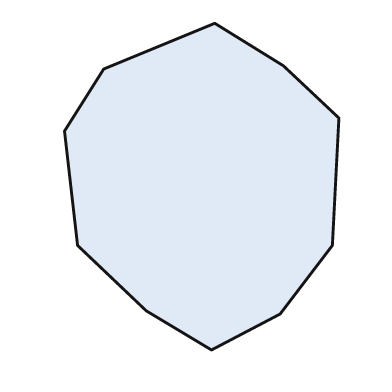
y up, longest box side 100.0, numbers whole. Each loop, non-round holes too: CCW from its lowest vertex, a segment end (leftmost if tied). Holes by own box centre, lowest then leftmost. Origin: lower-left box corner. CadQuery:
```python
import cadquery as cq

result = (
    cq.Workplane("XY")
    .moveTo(45.0, 0.0)
    .lineTo(66.0, 11.0)
    .lineTo(82.0, 32.0)
    .lineTo(84.0, 71.0)
    .lineTo(67.0, 87.0)
    .lineTo(46.0, 100.0)
    .lineTo(12.0, 86.0)
    .lineTo(0.0, 67.0)
    .lineTo(4.0, 32.0)
    .lineTo(25.0, 12.0)
    .close()
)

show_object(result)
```